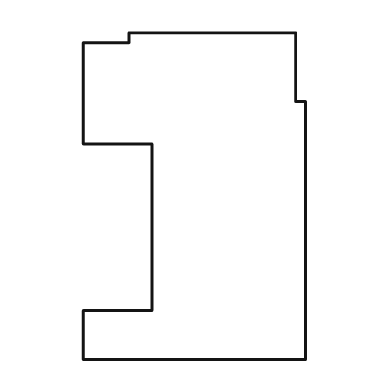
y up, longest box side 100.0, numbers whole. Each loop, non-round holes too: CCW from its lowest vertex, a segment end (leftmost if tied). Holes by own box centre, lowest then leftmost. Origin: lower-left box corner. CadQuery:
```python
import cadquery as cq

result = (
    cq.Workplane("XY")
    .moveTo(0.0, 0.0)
    .lineTo(68.0, 0.0)
    .lineTo(68.0, 79.0)
    .lineTo(65.0, 79.0)
    .lineTo(65.0, 100.0)
    .lineTo(14.0, 100.0)
    .lineTo(14.0, 97.0)
    .lineTo(0.0, 97.0)
    .lineTo(0.0, 66.0)
    .lineTo(21.0, 66.0)
    .lineTo(21.0, 15.0)
    .lineTo(0.0, 15.0)
    .close()
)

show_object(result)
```